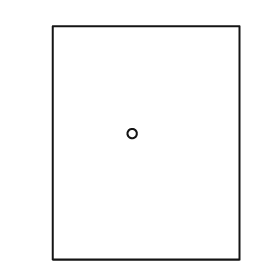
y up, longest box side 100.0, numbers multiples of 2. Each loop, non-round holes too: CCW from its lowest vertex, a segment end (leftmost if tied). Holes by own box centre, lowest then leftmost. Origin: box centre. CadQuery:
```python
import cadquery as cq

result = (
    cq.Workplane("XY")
    .moveTo(-40.0, -50.0)
    .lineTo(40.0, -50.0)
    .lineTo(40.0, 50.0)
    .lineTo(-40.0, 50.0)
    .close()
    .moveTo(-6.0, 4.0)
    .circle(2.0)
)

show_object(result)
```